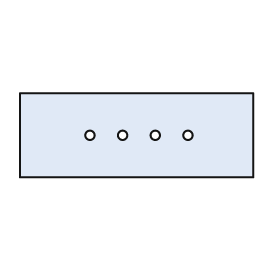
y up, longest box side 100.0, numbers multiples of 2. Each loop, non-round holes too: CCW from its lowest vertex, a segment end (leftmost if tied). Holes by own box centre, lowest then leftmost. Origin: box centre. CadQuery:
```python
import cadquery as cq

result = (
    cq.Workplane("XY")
    .moveTo(-50.0, -18.0)
    .lineTo(50.0, -18.0)
    .lineTo(50.0, 18.0)
    .lineTo(-50.0, 18.0)
    .close()
    .moveTo(-20.0, 0.0)
    .circle(2.0)
    .moveTo(-6.0, 0.0)
    .circle(2.0)
    .moveTo(8.0, 0.0)
    .circle(2.0)
    .moveTo(22.0, 0.0)
    .circle(2.0)
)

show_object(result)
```